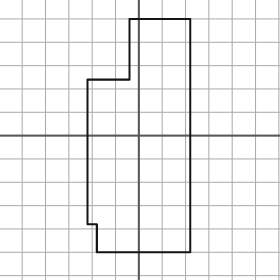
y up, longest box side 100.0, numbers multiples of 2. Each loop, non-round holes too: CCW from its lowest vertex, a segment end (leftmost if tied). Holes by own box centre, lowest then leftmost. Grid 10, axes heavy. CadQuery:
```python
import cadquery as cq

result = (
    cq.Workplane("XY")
    .moveTo(-18.0, -50.0)
    .lineTo(22.0, -50.0)
    .lineTo(22.0, 50.0)
    .lineTo(-4.0, 50.0)
    .lineTo(-4.0, 24.0)
    .lineTo(-22.0, 24.0)
    .lineTo(-22.0, -38.0)
    .lineTo(-18.0, -38.0)
    .close()
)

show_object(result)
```